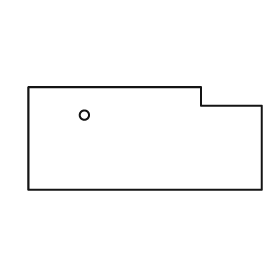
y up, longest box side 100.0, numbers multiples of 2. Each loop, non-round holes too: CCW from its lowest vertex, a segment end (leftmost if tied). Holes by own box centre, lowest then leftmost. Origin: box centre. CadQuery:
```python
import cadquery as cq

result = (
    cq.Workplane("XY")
    .moveTo(-50.0, -22.0)
    .lineTo(50.0, -22.0)
    .lineTo(50.0, 14.0)
    .lineTo(24.0, 14.0)
    .lineTo(24.0, 22.0)
    .lineTo(-50.0, 22.0)
    .close()
    .moveTo(-26.0, 10.0)
    .circle(2.0)
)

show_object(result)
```